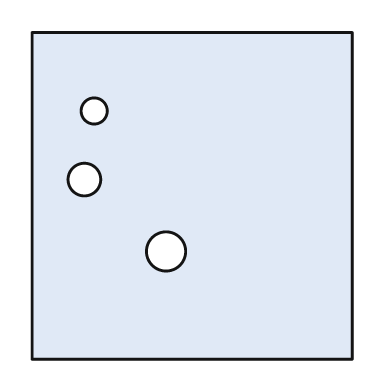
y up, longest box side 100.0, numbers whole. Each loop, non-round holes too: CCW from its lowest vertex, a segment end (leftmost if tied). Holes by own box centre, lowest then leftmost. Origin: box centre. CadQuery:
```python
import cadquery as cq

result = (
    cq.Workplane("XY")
    .moveTo(-49.0, -50.0)
    .lineTo(49.0, -50.0)
    .lineTo(49.0, 50.0)
    .lineTo(-49.0, 50.0)
    .close()
    .moveTo(-8.0, -17.0)
    .circle(6.0)
    .moveTo(-33.0, 5.0)
    .circle(5.0)
    .moveTo(-30.0, 26.0)
    .circle(4.0)
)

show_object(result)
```